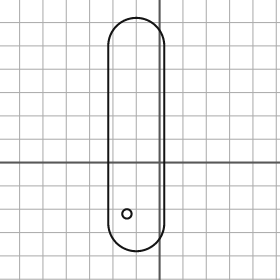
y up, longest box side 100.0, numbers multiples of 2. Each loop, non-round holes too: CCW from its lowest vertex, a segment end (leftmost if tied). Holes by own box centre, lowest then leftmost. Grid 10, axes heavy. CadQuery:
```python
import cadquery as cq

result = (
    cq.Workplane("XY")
    .moveTo(-22.0, -26.0)
    .threePointArc((-10.0, -38.0), (2.0, -26.0))
    .lineTo(2.0, 50.0)
    .threePointArc((-10.0, 62.0), (-22.0, 50.0))
    .close()
    .moveTo(-14.0, -22.0)
    .circle(2.0)
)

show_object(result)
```